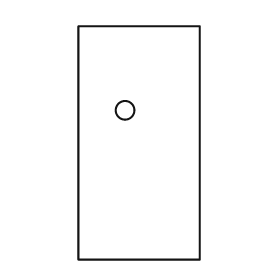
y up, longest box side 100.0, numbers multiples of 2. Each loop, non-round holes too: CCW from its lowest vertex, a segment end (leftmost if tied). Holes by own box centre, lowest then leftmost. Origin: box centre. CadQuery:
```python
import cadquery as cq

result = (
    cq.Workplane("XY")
    .moveTo(-26.0, -50.0)
    .lineTo(26.0, -50.0)
    .lineTo(26.0, 50.0)
    .lineTo(-26.0, 50.0)
    .close()
    .moveTo(-6.0, 14.0)
    .circle(4.0)
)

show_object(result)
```